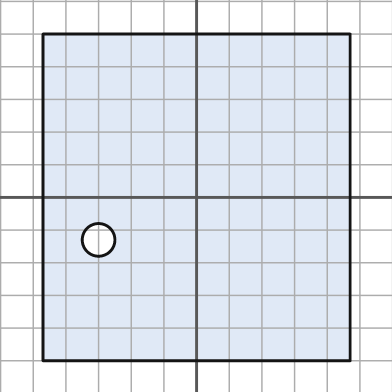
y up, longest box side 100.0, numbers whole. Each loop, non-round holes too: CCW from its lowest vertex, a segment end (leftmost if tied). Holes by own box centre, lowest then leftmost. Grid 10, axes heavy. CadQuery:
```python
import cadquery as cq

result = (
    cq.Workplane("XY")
    .moveTo(-47.0, -50.0)
    .lineTo(47.0, -50.0)
    .lineTo(47.0, 50.0)
    .lineTo(-47.0, 50.0)
    .close()
    .moveTo(-30.0, -13.0)
    .circle(5.0)
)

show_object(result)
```